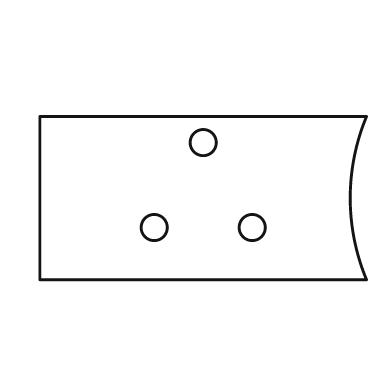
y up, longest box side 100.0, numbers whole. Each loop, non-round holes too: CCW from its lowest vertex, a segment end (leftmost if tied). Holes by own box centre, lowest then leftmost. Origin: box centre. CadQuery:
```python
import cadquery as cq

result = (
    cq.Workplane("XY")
    .moveTo(-50.0, -25.0)
    .lineTo(50.0, -25.0)
    .threePointArc((45.0, 0.0), (50.0, 25.0))
    .lineTo(-50.0, 25.0)
    .close()
    .moveTo(-15.0, -9.0)
    .circle(4.0)
    .moveTo(15.0, -9.0)
    .circle(4.0)
    .moveTo(0.0, 17.0)
    .circle(4.0)
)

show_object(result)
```